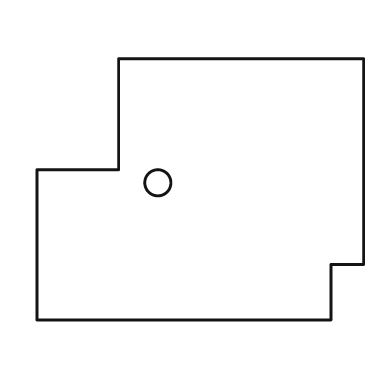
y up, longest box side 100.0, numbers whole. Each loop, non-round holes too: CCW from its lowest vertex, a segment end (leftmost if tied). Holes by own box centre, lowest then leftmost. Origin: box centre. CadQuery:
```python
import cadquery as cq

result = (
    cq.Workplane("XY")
    .moveTo(-50.0, -40.0)
    .lineTo(40.0, -40.0)
    .lineTo(40.0, -23.0)
    .lineTo(50.0, -23.0)
    .lineTo(50.0, 40.0)
    .lineTo(-25.0, 40.0)
    .lineTo(-25.0, 6.0)
    .lineTo(-50.0, 6.0)
    .close()
    .moveTo(-13.0, 2.0)
    .circle(4.0)
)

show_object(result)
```